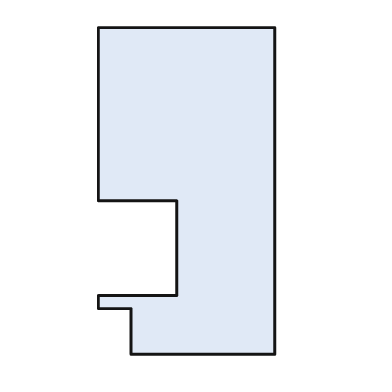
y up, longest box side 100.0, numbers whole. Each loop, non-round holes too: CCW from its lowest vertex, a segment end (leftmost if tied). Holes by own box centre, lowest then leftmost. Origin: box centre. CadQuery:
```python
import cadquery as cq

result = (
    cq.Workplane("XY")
    .moveTo(-17.0, -50.0)
    .lineTo(27.0, -50.0)
    .lineTo(27.0, 50.0)
    .lineTo(-27.0, 50.0)
    .lineTo(-27.0, -3.0)
    .lineTo(-3.0, -3.0)
    .lineTo(-3.0, -32.0)
    .lineTo(-27.0, -32.0)
    .lineTo(-27.0, -36.0)
    .lineTo(-17.0, -36.0)
    .close()
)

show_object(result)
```